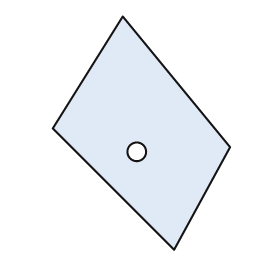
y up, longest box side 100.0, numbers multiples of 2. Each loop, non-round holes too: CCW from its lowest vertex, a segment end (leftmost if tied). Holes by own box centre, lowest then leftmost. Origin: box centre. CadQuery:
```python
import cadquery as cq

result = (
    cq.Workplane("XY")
    .moveTo(14.0, -50.0)
    .lineTo(38.0, -6.0)
    .lineTo(-8.0, 50.0)
    .lineTo(-38.0, 2.0)
    .close()
    .moveTo(-2.0, -8.0)
    .circle(4.0)
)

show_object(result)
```